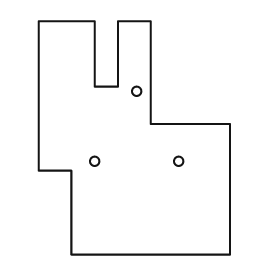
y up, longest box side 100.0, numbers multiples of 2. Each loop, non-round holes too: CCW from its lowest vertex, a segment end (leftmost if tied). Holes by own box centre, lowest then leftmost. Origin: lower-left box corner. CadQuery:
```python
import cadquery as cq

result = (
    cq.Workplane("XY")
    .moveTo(14.0, 0.0)
    .lineTo(82.0, 0.0)
    .lineTo(82.0, 56.0)
    .lineTo(48.0, 56.0)
    .lineTo(48.0, 100.0)
    .lineTo(34.0, 100.0)
    .lineTo(34.0, 72.0)
    .lineTo(24.0, 72.0)
    .lineTo(24.0, 100.0)
    .lineTo(0.0, 100.0)
    .lineTo(0.0, 36.0)
    .lineTo(14.0, 36.0)
    .close()
    .moveTo(24.0, 40.0)
    .circle(2.0)
    .moveTo(60.0, 40.0)
    .circle(2.0)
    .moveTo(42.0, 70.0)
    .circle(2.0)
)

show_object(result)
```